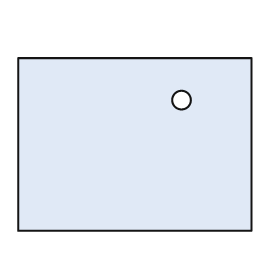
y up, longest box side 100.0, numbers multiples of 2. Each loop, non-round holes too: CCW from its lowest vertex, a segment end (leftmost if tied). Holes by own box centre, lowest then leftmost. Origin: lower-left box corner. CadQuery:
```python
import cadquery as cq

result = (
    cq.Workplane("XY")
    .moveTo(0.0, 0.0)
    .lineTo(100.0, 0.0)
    .lineTo(100.0, 74.0)
    .lineTo(0.0, 74.0)
    .close()
    .moveTo(70.0, 56.0)
    .circle(4.0)
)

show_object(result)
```